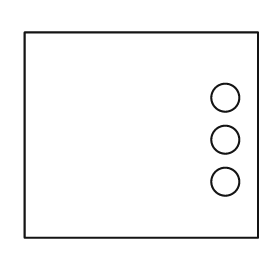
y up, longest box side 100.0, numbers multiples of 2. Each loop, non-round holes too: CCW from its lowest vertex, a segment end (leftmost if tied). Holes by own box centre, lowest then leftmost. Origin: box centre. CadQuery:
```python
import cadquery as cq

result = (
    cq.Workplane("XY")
    .moveTo(-50.0, -44.0)
    .lineTo(50.0, -44.0)
    .lineTo(50.0, 44.0)
    .lineTo(-50.0, 44.0)
    .close()
    .moveTo(36.0, -20.0)
    .circle(6.0)
    .moveTo(36.0, -2.0)
    .circle(6.0)
    .moveTo(36.0, 16.0)
    .circle(6.0)
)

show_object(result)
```